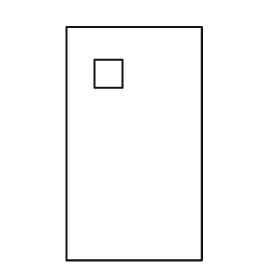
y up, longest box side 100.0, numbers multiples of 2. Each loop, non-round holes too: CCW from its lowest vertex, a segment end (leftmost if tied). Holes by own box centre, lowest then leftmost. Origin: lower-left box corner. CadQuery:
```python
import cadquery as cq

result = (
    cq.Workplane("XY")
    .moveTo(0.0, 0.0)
    .lineTo(58.0, 0.0)
    .lineTo(58.0, 100.0)
    .lineTo(0.0, 100.0)
    .close()
    .moveTo(12.0, 74.0)
    .lineTo(24.0, 74.0)
    .lineTo(24.0, 86.0)
    .lineTo(12.0, 86.0)
    .close()
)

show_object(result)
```